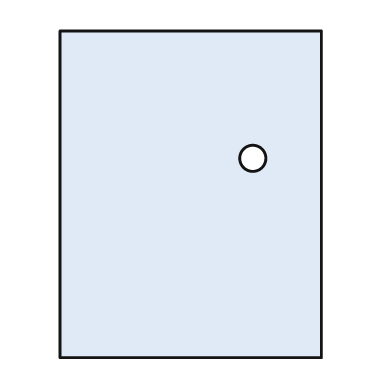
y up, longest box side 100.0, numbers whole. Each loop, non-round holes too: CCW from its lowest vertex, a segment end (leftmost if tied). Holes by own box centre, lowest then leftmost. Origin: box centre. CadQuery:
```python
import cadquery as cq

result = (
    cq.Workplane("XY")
    .moveTo(-40.0, -50.0)
    .lineTo(40.0, -50.0)
    .lineTo(40.0, 50.0)
    .lineTo(-40.0, 50.0)
    .close()
    .moveTo(19.0, 11.0)
    .circle(4.0)
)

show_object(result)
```